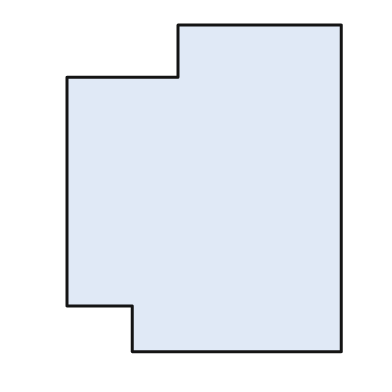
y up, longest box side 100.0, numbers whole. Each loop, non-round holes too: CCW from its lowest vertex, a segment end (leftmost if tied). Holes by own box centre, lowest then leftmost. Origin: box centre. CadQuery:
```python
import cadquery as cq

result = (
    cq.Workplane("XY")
    .moveTo(-22.0, -50.0)
    .lineTo(42.0, -50.0)
    .lineTo(42.0, 50.0)
    .lineTo(-8.0, 50.0)
    .lineTo(-8.0, 34.0)
    .lineTo(-42.0, 34.0)
    .lineTo(-42.0, -36.0)
    .lineTo(-22.0, -36.0)
    .close()
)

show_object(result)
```